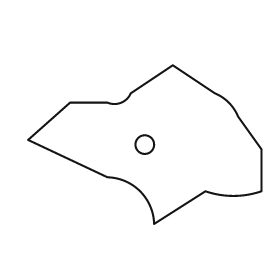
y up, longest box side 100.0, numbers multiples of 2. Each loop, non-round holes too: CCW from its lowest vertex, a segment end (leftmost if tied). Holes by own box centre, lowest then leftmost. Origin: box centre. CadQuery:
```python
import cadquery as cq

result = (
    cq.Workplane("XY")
    .moveTo(4.0, -34.0)
    .lineTo(26.0, -20.0)
    .threePointArc((38.0, -22.0), (50.0, -20.0))
    .lineTo(50.0, -2.0)
    .lineTo(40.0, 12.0)
    .threePointArc((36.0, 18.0), (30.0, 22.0))
    .lineTo(12.0, 34.0)
    .lineTo(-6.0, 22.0)
    .threePointArc((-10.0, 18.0), (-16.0, 18.0))
    .lineTo(-32.0, 18.0)
    .lineTo(-50.0, 2.0)
    .lineTo(-16.0, -14.0)
    .threePointArc((-2.0, -20.0), (4.0, -34.0))
    .close()
    .moveTo(0.0, 0.0)
    .circle(4.0)
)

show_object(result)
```